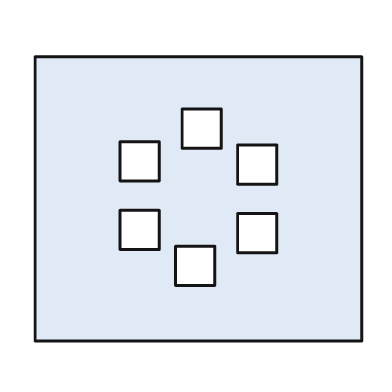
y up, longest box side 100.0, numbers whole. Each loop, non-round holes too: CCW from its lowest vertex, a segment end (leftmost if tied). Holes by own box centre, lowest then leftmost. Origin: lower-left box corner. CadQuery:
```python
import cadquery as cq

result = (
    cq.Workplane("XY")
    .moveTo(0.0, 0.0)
    .lineTo(100.0, 0.0)
    .lineTo(100.0, 87.0)
    .lineTo(0.0, 87.0)
    .close()
    .moveTo(43.0, 17.0)
    .lineTo(55.0, 17.0)
    .lineTo(55.0, 29.0)
    .lineTo(43.0, 29.0)
    .close()
    .moveTo(62.0, 27.0)
    .lineTo(74.0, 27.0)
    .lineTo(74.0, 39.0)
    .lineTo(62.0, 39.0)
    .close()
    .moveTo(26.0, 28.0)
    .lineTo(38.0, 28.0)
    .lineTo(38.0, 40.0)
    .lineTo(26.0, 40.0)
    .close()
    .moveTo(62.0, 48.0)
    .lineTo(74.0, 48.0)
    .lineTo(74.0, 60.0)
    .lineTo(62.0, 60.0)
    .close()
    .moveTo(26.0, 49.0)
    .lineTo(38.0, 49.0)
    .lineTo(38.0, 61.0)
    .lineTo(26.0, 61.0)
    .close()
    .moveTo(45.0, 59.0)
    .lineTo(57.0, 59.0)
    .lineTo(57.0, 71.0)
    .lineTo(45.0, 71.0)
    .close()
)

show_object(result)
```